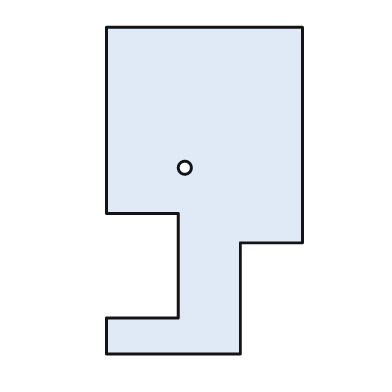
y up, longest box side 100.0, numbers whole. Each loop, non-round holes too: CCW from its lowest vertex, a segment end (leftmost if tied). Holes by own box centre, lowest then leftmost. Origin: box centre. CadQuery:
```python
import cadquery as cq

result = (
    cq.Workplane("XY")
    .moveTo(-30.0, -50.0)
    .lineTo(11.0, -50.0)
    .lineTo(11.0, -16.0)
    .lineTo(30.0, -16.0)
    .lineTo(30.0, 50.0)
    .lineTo(-30.0, 50.0)
    .lineTo(-30.0, -7.0)
    .lineTo(-8.0, -7.0)
    .lineTo(-8.0, -39.0)
    .lineTo(-30.0, -39.0)
    .close()
    .moveTo(-6.0, 7.0)
    .circle(2.0)
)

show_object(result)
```